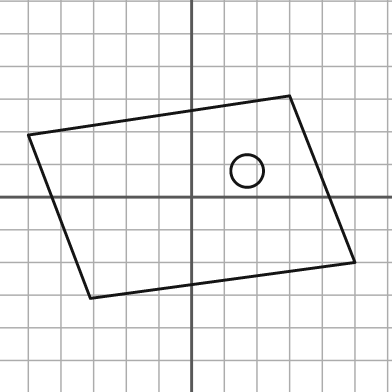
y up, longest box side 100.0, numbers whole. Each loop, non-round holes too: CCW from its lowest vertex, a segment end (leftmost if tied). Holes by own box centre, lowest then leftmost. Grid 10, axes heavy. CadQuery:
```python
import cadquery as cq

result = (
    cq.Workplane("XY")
    .moveTo(-31.0, -31.0)
    .lineTo(50.0, -20.0)
    .lineTo(30.0, 31.0)
    .lineTo(-50.0, 19.0)
    .close()
    .moveTo(17.0, 8.0)
    .circle(5.0)
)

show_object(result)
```